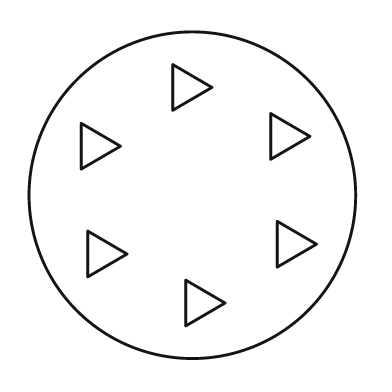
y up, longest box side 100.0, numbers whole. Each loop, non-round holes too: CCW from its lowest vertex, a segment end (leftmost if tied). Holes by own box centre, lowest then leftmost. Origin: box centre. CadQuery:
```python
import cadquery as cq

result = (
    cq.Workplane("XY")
    .moveTo(0.0, 0.0)
    .circle(50.0)
    .moveTo(-2.0, -40.0)
    .lineTo(10.0, -33.0)
    .lineTo(-2.0, -26.0)
    .close()
    .moveTo(-32.0, -25.0)
    .lineTo(-20.0, -18.0)
    .lineTo(-32.0, -11.0)
    .close()
    .moveTo(26.0, -22.0)
    .lineTo(38.0, -15.0)
    .lineTo(26.0, -8.0)
    .close()
    .moveTo(-34.0, 8.0)
    .lineTo(-22.0, 15.0)
    .lineTo(-34.0, 22.0)
    .close()
    .moveTo(24.0, 11.0)
    .lineTo(36.0, 18.0)
    .lineTo(24.0, 25.0)
    .close()
    .moveTo(-6.0, 26.0)
    .lineTo(6.0, 33.0)
    .lineTo(-6.0, 40.0)
    .close()
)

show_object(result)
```